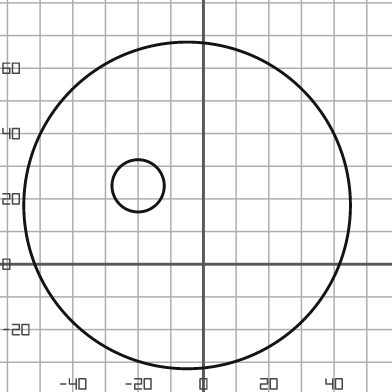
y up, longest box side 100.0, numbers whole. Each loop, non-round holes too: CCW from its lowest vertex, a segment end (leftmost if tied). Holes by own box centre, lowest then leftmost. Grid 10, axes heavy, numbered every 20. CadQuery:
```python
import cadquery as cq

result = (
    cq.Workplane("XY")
    .moveTo(-5.0, 18.0)
    .circle(50.0)
    .moveTo(-20.0, 24.0)
    .circle(8.0)
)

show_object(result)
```